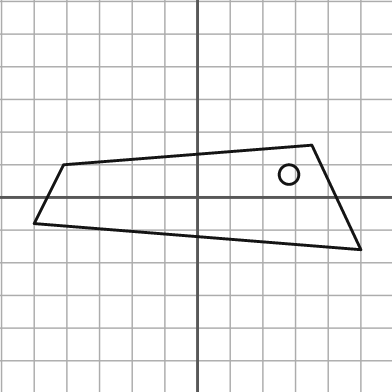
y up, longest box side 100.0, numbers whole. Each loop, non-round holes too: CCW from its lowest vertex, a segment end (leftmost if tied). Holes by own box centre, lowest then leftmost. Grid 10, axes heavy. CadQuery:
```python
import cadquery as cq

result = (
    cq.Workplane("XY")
    .moveTo(50.0, -16.0)
    .lineTo(35.0, 16.0)
    .lineTo(-41.0, 10.0)
    .lineTo(-50.0, -8.0)
    .close()
    .moveTo(28.0, 7.0)
    .circle(3.0)
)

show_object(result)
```